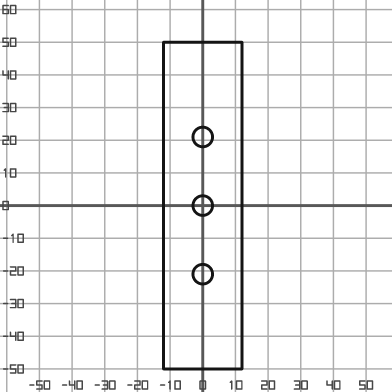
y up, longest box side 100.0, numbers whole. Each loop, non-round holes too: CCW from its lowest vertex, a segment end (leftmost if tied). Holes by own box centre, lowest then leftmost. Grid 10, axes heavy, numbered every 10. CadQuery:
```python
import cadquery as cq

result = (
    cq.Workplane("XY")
    .moveTo(-12.0, -50.0)
    .lineTo(12.0, -50.0)
    .lineTo(12.0, 50.0)
    .lineTo(-12.0, 50.0)
    .close()
    .moveTo(0.0, -21.0)
    .circle(3.0)
    .moveTo(0.0, 0.0)
    .circle(3.0)
    .moveTo(0.0, 21.0)
    .circle(3.0)
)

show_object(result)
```